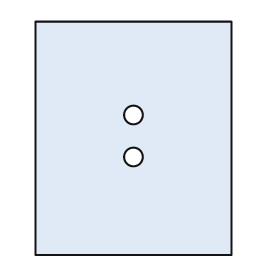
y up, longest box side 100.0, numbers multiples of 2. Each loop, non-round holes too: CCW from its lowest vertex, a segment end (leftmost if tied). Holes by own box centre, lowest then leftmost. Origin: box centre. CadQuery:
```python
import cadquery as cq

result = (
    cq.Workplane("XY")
    .moveTo(-42.0, -50.0)
    .lineTo(42.0, -50.0)
    .lineTo(42.0, 50.0)
    .lineTo(-42.0, 50.0)
    .close()
    .moveTo(0.0, -8.0)
    .circle(4.0)
    .moveTo(0.0, 10.0)
    .circle(4.0)
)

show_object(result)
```